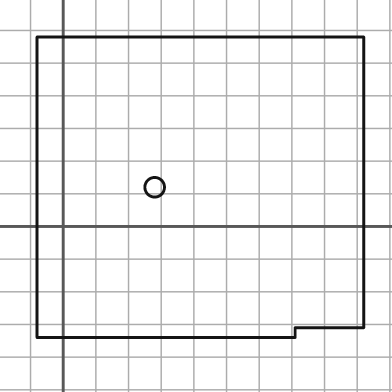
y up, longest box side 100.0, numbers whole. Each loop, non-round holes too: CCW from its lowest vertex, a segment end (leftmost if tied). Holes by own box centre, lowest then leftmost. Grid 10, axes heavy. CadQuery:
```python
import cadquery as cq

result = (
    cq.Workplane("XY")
    .moveTo(-8.0, -34.0)
    .lineTo(71.0, -34.0)
    .lineTo(71.0, -31.0)
    .lineTo(92.0, -31.0)
    .lineTo(92.0, 58.0)
    .lineTo(-8.0, 58.0)
    .close()
    .moveTo(28.0, 12.0)
    .circle(3.0)
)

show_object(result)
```